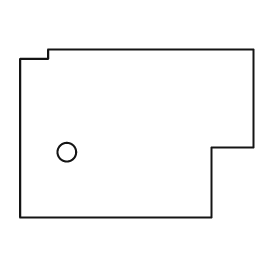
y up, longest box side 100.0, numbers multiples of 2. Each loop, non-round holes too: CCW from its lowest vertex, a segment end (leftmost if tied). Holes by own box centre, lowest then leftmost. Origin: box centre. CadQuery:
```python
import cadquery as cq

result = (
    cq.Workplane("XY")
    .moveTo(-50.0, -36.0)
    .lineTo(32.0, -36.0)
    .lineTo(32.0, -6.0)
    .lineTo(50.0, -6.0)
    .lineTo(50.0, 36.0)
    .lineTo(-38.0, 36.0)
    .lineTo(-38.0, 32.0)
    .lineTo(-50.0, 32.0)
    .close()
    .moveTo(-30.0, -8.0)
    .circle(4.0)
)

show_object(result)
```